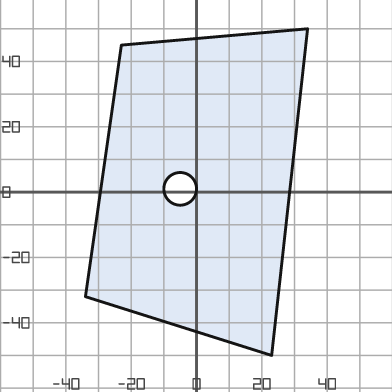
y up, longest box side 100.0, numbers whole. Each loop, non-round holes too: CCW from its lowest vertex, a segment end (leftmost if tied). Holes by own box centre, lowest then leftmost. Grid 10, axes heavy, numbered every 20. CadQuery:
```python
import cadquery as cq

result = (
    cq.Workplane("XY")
    .moveTo(23.0, -50.0)
    .lineTo(34.0, 50.0)
    .lineTo(-23.0, 45.0)
    .lineTo(-34.0, -32.0)
    .close()
    .moveTo(-5.0, 1.0)
    .circle(5.0)
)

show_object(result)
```